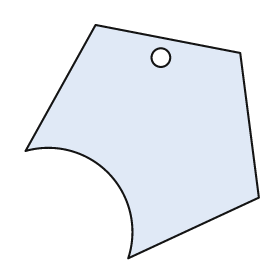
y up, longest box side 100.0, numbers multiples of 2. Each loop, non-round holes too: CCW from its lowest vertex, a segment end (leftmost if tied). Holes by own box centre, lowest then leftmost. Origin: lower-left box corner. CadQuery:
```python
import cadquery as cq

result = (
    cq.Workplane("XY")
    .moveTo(44.0, 0.0)
    .lineTo(100.0, 26.0)
    .lineTo(92.0, 88.0)
    .lineTo(30.0, 100.0)
    .lineTo(0.0, 46.0)
    .threePointArc((36.0, 36.0), (44.0, 0.0))
    .close()
    .moveTo(58.0, 86.0)
    .circle(4.0)
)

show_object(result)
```